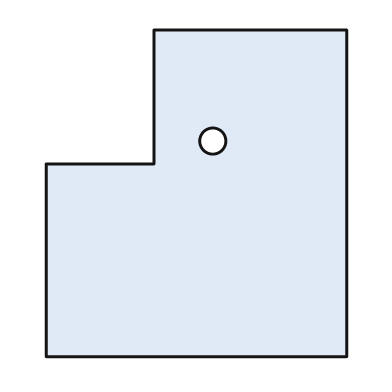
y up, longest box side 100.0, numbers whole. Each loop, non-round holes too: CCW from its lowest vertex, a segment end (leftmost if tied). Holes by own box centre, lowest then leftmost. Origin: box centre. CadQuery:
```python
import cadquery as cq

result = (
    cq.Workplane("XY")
    .moveTo(-46.0, -50.0)
    .lineTo(46.0, -50.0)
    .lineTo(46.0, 50.0)
    .lineTo(-13.0, 50.0)
    .lineTo(-13.0, 9.0)
    .lineTo(-46.0, 9.0)
    .close()
    .moveTo(5.0, 16.0)
    .circle(4.0)
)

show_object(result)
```